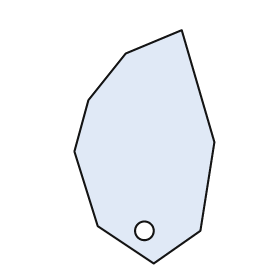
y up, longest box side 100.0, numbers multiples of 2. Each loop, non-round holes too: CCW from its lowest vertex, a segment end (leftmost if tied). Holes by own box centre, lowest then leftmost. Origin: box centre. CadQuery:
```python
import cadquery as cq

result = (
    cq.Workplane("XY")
    .moveTo(4.0, -50.0)
    .lineTo(24.0, -36.0)
    .lineTo(30.0, 2.0)
    .lineTo(16.0, 50.0)
    .lineTo(-8.0, 40.0)
    .lineTo(-24.0, 20.0)
    .lineTo(-30.0, -2.0)
    .lineTo(-20.0, -34.0)
    .close()
    .moveTo(0.0, -36.0)
    .circle(4.0)
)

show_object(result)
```